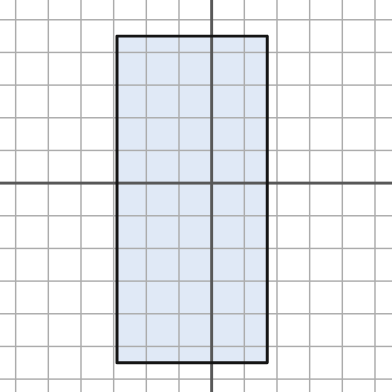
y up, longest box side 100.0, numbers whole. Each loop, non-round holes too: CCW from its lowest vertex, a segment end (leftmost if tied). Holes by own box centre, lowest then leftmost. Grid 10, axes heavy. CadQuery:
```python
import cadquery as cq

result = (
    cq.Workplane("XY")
    .moveTo(-29.0, -55.0)
    .lineTo(17.0, -55.0)
    .lineTo(17.0, 45.0)
    .lineTo(-29.0, 45.0)
    .close()
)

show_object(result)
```